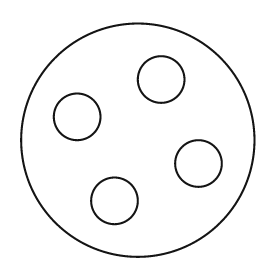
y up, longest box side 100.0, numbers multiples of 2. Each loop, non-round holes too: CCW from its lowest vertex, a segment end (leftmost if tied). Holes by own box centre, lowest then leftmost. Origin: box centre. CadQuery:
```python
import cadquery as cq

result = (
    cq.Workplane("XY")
    .moveTo(0.0, 0.0)
    .circle(50.0)
    .moveTo(-10.0, -26.0)
    .circle(10.0)
    .moveTo(26.0, -10.0)
    .circle(10.0)
    .moveTo(-26.0, 10.0)
    .circle(10.0)
    .moveTo(10.0, 26.0)
    .circle(10.0)
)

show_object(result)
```